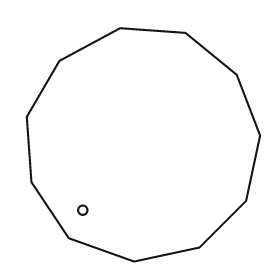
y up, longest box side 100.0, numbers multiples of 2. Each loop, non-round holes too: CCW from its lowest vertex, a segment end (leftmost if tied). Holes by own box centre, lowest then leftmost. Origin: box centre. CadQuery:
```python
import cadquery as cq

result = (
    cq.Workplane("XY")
    .moveTo(-4.0, -50.0)
    .lineTo(24.0, -44.0)
    .lineTo(44.0, -24.0)
    .lineTo(50.0, 4.0)
    .lineTo(40.0, 30.0)
    .lineTo(18.0, 48.0)
    .lineTo(-10.0, 50.0)
    .lineTo(-36.0, 36.0)
    .lineTo(-50.0, 12.0)
    .lineTo(-48.0, -16.0)
    .lineTo(-32.0, -40.0)
    .close()
    .moveTo(-26.0, -28.0)
    .circle(2.0)
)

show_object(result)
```